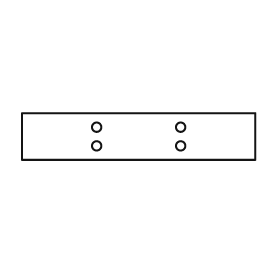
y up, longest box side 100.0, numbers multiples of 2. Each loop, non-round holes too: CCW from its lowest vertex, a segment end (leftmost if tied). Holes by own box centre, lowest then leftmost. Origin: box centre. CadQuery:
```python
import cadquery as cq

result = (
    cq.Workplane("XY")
    .moveTo(-50.0, -10.0)
    .lineTo(50.0, -10.0)
    .lineTo(50.0, 10.0)
    .lineTo(-50.0, 10.0)
    .close()
    .moveTo(-18.0, -4.0)
    .circle(2.0)
    .moveTo(18.0, -4.0)
    .circle(2.0)
    .moveTo(-18.0, 4.0)
    .circle(2.0)
    .moveTo(18.0, 4.0)
    .circle(2.0)
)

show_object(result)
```